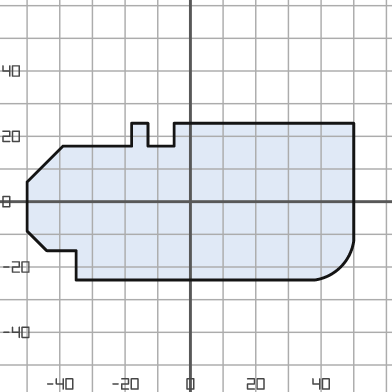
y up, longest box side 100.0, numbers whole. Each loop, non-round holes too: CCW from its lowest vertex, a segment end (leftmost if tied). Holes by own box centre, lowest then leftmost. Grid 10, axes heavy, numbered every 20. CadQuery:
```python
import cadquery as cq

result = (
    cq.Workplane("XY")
    .moveTo(-35.0, -24.0)
    .lineTo(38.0, -24.0)
    .threePointArc((46.0, -20.0), (50.0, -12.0))
    .lineTo(50.0, 24.0)
    .lineTo(-5.0, 24.0)
    .lineTo(-5.0, 17.0)
    .lineTo(-13.0, 17.0)
    .lineTo(-13.0, 24.0)
    .lineTo(-18.0, 24.0)
    .lineTo(-18.0, 17.0)
    .lineTo(-39.0, 17.0)
    .lineTo(-50.0, 6.0)
    .lineTo(-50.0, -9.0)
    .lineTo(-44.0, -15.0)
    .lineTo(-35.0, -15.0)
    .close()
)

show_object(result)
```